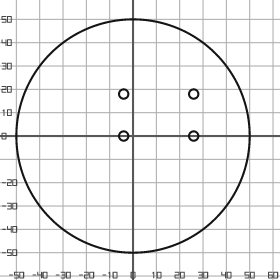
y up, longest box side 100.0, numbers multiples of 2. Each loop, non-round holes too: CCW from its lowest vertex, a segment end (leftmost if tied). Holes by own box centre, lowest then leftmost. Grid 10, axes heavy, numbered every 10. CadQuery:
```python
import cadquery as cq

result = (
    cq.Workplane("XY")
    .moveTo(0.0, 0.0)
    .circle(50.0)
    .moveTo(-4.0, 0.0)
    .circle(2.0)
    .moveTo(26.0, 0.0)
    .circle(2.0)
    .moveTo(-4.0, 18.0)
    .circle(2.0)
    .moveTo(26.0, 18.0)
    .circle(2.0)
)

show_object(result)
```